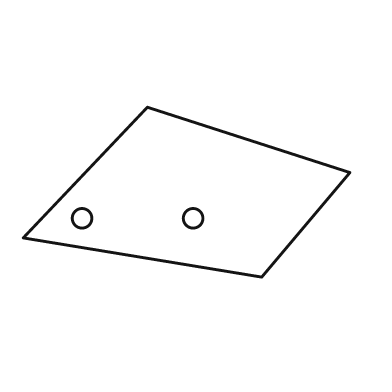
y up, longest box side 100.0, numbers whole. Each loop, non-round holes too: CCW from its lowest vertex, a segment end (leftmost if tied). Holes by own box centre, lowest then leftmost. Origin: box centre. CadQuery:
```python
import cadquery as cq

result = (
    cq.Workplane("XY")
    .moveTo(23.0, -26.0)
    .lineTo(50.0, 6.0)
    .lineTo(-12.0, 26.0)
    .lineTo(-50.0, -14.0)
    .close()
    .moveTo(-32.0, -8.0)
    .circle(3.0)
    .moveTo(2.0, -8.0)
    .circle(3.0)
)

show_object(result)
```